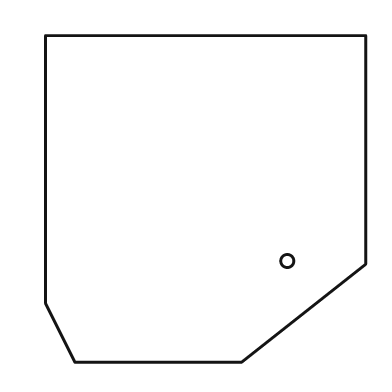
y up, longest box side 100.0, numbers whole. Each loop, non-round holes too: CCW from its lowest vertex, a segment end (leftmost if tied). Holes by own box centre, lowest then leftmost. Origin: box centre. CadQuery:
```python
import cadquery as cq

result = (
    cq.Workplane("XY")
    .moveTo(-40.0, -50.0)
    .lineTo(11.0, -50.0)
    .lineTo(49.0, -20.0)
    .lineTo(49.0, 50.0)
    .lineTo(-49.0, 50.0)
    .lineTo(-49.0, -32.0)
    .close()
    .moveTo(25.0, -19.0)
    .circle(2.0)
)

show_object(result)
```